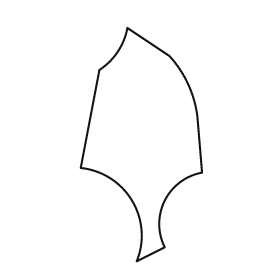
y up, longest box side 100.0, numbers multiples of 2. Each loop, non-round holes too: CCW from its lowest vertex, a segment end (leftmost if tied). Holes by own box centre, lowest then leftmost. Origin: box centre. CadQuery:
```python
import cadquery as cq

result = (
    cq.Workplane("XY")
    .moveTo(-2.0, -50.0)
    .lineTo(10.0, -44.0)
    .threePointArc((10.0, -24.0), (26.0, -12.0))
    .lineTo(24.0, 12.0)
    .threePointArc((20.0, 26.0), (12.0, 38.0))
    .lineTo(-6.0, 50.0)
    .threePointArc((-10.0, 40.0), (-18.0, 32.0))
    .lineTo(-26.0, -10.0)
    .threePointArc((-4.0, -24.0), (-2.0, -50.0))
    .close()
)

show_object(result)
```